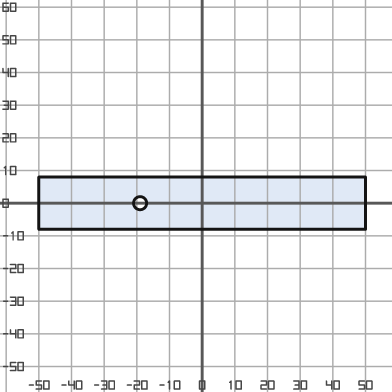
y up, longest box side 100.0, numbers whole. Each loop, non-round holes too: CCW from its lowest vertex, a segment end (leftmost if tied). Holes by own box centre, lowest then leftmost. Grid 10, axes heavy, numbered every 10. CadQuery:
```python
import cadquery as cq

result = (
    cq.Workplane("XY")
    .moveTo(-50.0, -8.0)
    .lineTo(50.0, -8.0)
    .lineTo(50.0, 8.0)
    .lineTo(-50.0, 8.0)
    .close()
    .moveTo(-19.0, 0.0)
    .circle(2.0)
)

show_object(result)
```